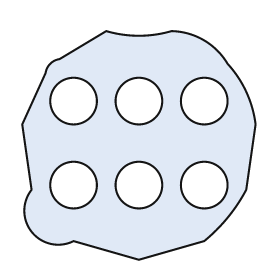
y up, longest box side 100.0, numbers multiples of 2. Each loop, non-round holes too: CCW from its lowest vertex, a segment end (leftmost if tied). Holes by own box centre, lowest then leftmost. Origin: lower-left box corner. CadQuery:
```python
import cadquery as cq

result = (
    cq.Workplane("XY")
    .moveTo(50.0, 0.0)
    .lineTo(78.0, 8.0)
    .threePointArc((88.0, 18.0), (96.0, 30.0))
    .lineTo(100.0, 58.0)
    .threePointArc((96.0, 72.0), (88.0, 84.0))
    .threePointArc((78.0, 94.0), (64.0, 98.0))
    .threePointArc((50.0, 96.0), (36.0, 98.0))
    .lineTo(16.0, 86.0)
    .threePointArc((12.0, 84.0), (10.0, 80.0))
    .lineTo(0.0, 58.0)
    .lineTo(4.0, 30.0)
    .threePointArc((4.0, 12.0), (22.0, 8.0))
    .close()
    .moveTo(22.0, 32.0)
    .circle(10.0)
    .moveTo(50.0, 32.0)
    .circle(10.0)
    .moveTo(78.0, 32.0)
    .circle(10.0)
    .moveTo(22.0, 68.0)
    .circle(10.0)
    .moveTo(50.0, 68.0)
    .circle(10.0)
    .moveTo(78.0, 68.0)
    .circle(10.0)
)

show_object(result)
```